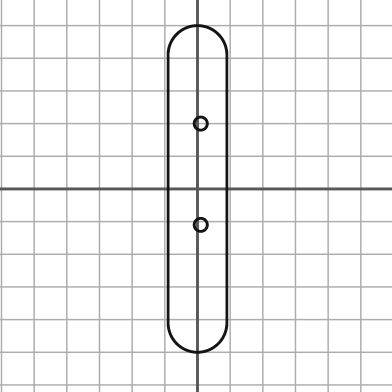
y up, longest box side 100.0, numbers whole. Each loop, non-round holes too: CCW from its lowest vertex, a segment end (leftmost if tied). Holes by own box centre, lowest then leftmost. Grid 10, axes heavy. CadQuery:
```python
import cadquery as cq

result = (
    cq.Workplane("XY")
    .moveTo(-9.0, -41.0)
    .threePointArc((0.0, -50.0), (9.0, -41.0))
    .lineTo(9.0, 41.0)
    .threePointArc((0.0, 50.0), (-9.0, 41.0))
    .close()
    .moveTo(1.0, -11.0)
    .circle(2.0)
    .moveTo(1.0, 20.0)
    .circle(2.0)
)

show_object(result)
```